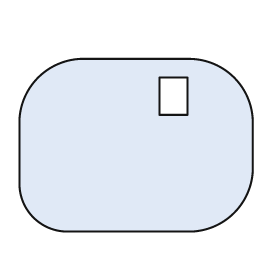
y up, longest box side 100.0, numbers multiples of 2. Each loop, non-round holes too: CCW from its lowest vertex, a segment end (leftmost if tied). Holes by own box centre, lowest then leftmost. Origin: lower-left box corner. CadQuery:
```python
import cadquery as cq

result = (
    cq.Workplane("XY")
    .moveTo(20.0, 0.0)
    .lineTo(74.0, 0.0)
    .threePointArc((92.0, 8.0), (100.0, 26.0))
    .lineTo(100.0, 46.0)
    .threePointArc((92.0, 66.0), (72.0, 74.0))
    .lineTo(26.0, 74.0)
    .threePointArc((8.0, 66.0), (0.0, 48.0))
    .lineTo(0.0, 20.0)
    .threePointArc((6.0, 6.0), (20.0, 0.0))
    .close()
    .moveTo(60.0, 50.0)
    .lineTo(72.0, 50.0)
    .lineTo(72.0, 66.0)
    .lineTo(60.0, 66.0)
    .close()
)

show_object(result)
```